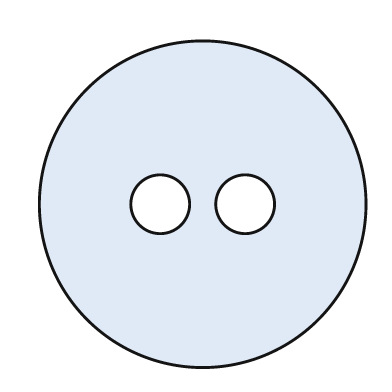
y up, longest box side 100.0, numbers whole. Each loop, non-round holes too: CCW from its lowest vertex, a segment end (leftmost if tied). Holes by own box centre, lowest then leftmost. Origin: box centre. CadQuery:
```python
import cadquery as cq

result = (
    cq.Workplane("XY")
    .moveTo(0.0, 0.0)
    .circle(50.0)
    .moveTo(-13.0, 0.0)
    .circle(9.0)
    .moveTo(13.0, 0.0)
    .circle(9.0)
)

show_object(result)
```